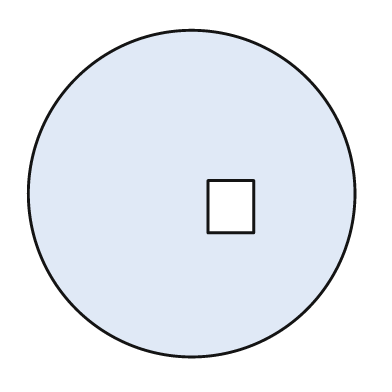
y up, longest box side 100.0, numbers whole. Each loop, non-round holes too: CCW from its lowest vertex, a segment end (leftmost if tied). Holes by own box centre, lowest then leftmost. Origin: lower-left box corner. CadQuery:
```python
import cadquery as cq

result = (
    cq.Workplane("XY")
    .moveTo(50.0, 50.0)
    .circle(50.0)
    .moveTo(55.0, 38.0)
    .lineTo(69.0, 38.0)
    .lineTo(69.0, 54.0)
    .lineTo(55.0, 54.0)
    .close()
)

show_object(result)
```